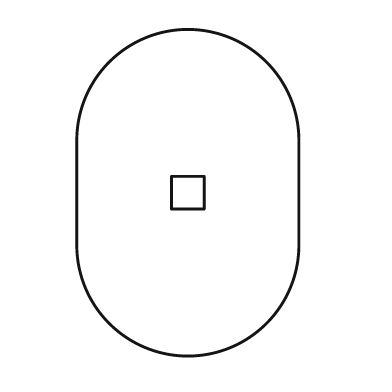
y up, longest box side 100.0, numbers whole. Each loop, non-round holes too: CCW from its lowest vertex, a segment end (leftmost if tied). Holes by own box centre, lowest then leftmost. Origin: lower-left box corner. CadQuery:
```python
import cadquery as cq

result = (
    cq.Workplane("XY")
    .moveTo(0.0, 34.0)
    .threePointArc((34.0, 0.0), (68.0, 34.0))
    .lineTo(68.0, 66.0)
    .threePointArc((34.0, 100.0), (0.0, 66.0))
    .close()
    .moveTo(29.0, 45.0)
    .lineTo(39.0, 45.0)
    .lineTo(39.0, 55.0)
    .lineTo(29.0, 55.0)
    .close()
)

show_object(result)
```